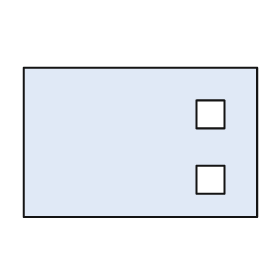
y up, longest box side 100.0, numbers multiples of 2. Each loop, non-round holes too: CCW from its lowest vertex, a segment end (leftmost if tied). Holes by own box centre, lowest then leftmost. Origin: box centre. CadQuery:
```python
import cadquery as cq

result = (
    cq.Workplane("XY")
    .moveTo(-50.0, -32.0)
    .lineTo(50.0, -32.0)
    .lineTo(50.0, 32.0)
    .lineTo(-50.0, 32.0)
    .close()
    .moveTo(24.0, -22.0)
    .lineTo(36.0, -22.0)
    .lineTo(36.0, -10.0)
    .lineTo(24.0, -10.0)
    .close()
    .moveTo(24.0, 6.0)
    .lineTo(36.0, 6.0)
    .lineTo(36.0, 18.0)
    .lineTo(24.0, 18.0)
    .close()
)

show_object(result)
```